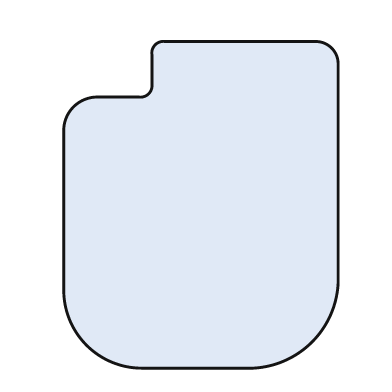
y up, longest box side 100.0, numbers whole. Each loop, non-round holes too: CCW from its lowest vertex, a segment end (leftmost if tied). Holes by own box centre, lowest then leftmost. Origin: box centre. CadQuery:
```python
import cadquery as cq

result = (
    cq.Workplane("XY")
    .moveTo(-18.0, -50.0)
    .lineTo(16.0, -50.0)
    .threePointArc((34.0, -42.0), (42.0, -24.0))
    .lineTo(42.0, 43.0)
    .threePointArc((40.0, 48.0), (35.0, 50.0))
    .lineTo(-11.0, 50.0)
    .threePointArc((-14.0, 49.0), (-15.0, 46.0))
    .lineTo(-15.0, 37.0)
    .threePointArc((-16.0, 34.0), (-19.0, 33.0))
    .lineTo(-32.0, 33.0)
    .threePointArc((-39.0, 30.0), (-42.0, 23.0))
    .lineTo(-42.0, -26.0)
    .threePointArc((-35.0, -43.0), (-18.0, -50.0))
    .close()
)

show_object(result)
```